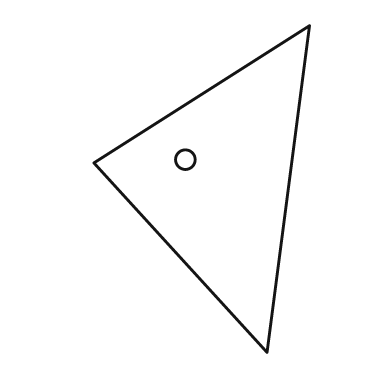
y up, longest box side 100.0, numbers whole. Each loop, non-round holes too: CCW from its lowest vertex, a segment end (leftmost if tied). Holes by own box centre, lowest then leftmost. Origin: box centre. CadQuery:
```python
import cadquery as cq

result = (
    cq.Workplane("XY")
    .moveTo(20.0, -50.0)
    .lineTo(33.0, 50.0)
    .lineTo(-33.0, 8.0)
    .close()
    .moveTo(-5.0, 9.0)
    .circle(3.0)
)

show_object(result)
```